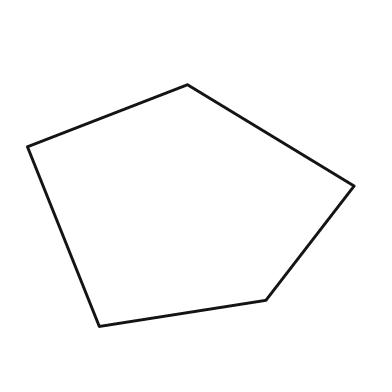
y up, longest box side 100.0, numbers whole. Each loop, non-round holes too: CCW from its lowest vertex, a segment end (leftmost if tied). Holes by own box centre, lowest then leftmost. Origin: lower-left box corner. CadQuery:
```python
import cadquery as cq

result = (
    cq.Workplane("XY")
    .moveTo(22.0, 0.0)
    .lineTo(73.0, 8.0)
    .lineTo(100.0, 43.0)
    .lineTo(49.0, 74.0)
    .lineTo(0.0, 55.0)
    .close()
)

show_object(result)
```